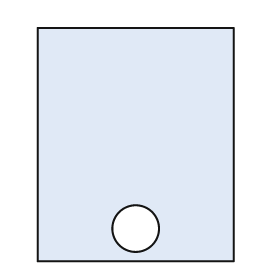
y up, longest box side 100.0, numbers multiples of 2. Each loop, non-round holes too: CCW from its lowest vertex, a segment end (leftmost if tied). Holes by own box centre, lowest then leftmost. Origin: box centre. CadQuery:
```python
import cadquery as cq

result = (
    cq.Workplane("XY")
    .moveTo(-42.0, -50.0)
    .lineTo(42.0, -50.0)
    .lineTo(42.0, 50.0)
    .lineTo(-42.0, 50.0)
    .close()
    .moveTo(0.0, -36.0)
    .circle(10.0)
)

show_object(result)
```